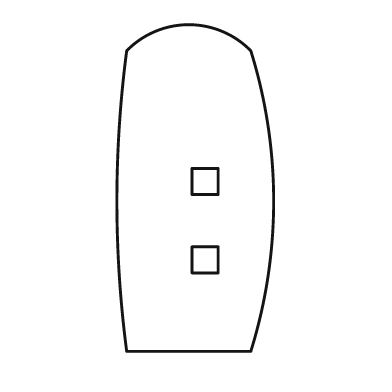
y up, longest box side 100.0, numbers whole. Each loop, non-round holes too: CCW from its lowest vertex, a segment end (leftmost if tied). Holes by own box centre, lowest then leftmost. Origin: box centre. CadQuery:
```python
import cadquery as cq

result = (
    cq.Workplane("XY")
    .moveTo(-21.0, -50.0)
    .lineTo(17.0, -50.0)
    .threePointArc((24.0, -4.0), (17.0, 42.0))
    .threePointArc((-2.0, 50.0), (-21.0, 42.0))
    .threePointArc((-24.0, -4.0), (-21.0, -50.0))
    .close()
    .moveTo(-1.0, -26.0)
    .lineTo(7.0, -26.0)
    .lineTo(7.0, -18.0)
    .lineTo(-1.0, -18.0)
    .close()
    .moveTo(-1.0, -2.0)
    .lineTo(7.0, -2.0)
    .lineTo(7.0, 6.0)
    .lineTo(-1.0, 6.0)
    .close()
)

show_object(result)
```